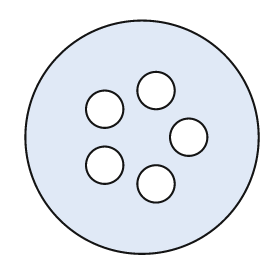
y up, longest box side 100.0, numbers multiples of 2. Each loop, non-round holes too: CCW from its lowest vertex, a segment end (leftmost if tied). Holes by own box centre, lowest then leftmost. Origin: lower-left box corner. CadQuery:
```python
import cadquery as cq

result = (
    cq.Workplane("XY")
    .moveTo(50.0, 50.0)
    .circle(50.0)
    .moveTo(56.0, 30.0)
    .circle(8.0)
    .moveTo(34.0, 38.0)
    .circle(8.0)
    .moveTo(70.0, 50.0)
    .circle(8.0)
    .moveTo(34.0, 62.0)
    .circle(8.0)
    .moveTo(56.0, 70.0)
    .circle(8.0)
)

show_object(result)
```